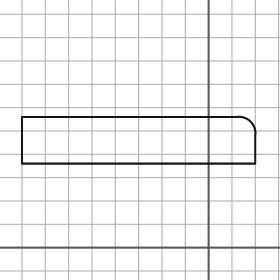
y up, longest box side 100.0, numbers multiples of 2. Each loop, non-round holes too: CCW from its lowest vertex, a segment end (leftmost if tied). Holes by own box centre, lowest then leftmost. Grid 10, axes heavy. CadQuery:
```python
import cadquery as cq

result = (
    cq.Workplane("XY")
    .moveTo(-80.0, 36.0)
    .lineTo(20.0, 36.0)
    .lineTo(20.0, 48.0)
    .threePointArc((18.0, 54.0), (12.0, 56.0))
    .lineTo(-80.0, 56.0)
    .close()
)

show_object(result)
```